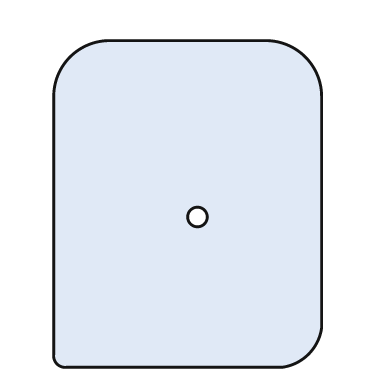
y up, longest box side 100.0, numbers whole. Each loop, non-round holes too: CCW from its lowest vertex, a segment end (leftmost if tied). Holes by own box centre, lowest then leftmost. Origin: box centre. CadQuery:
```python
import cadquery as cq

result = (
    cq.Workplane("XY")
    .moveTo(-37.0, -50.0)
    .lineTo(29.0, -50.0)
    .threePointArc((37.0, -46.0), (41.0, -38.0))
    .lineTo(41.0, 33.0)
    .threePointArc((36.0, 45.0), (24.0, 50.0))
    .lineTo(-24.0, 50.0)
    .threePointArc((-36.0, 45.0), (-41.0, 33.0))
    .lineTo(-41.0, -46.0)
    .threePointArc((-40.0, -49.0), (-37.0, -50.0))
    .close()
    .moveTo(3.0, -4.0)
    .circle(3.0)
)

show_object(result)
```